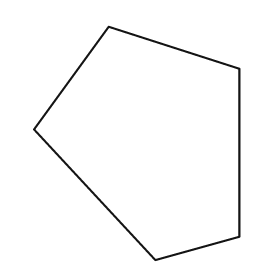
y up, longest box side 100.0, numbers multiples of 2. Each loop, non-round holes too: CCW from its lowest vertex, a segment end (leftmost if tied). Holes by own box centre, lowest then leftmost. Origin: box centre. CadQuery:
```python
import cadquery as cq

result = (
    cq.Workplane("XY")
    .moveTo(8.0, -50.0)
    .lineTo(44.0, -40.0)
    .lineTo(44.0, 32.0)
    .lineTo(-12.0, 50.0)
    .lineTo(-44.0, 6.0)
    .close()
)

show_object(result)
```